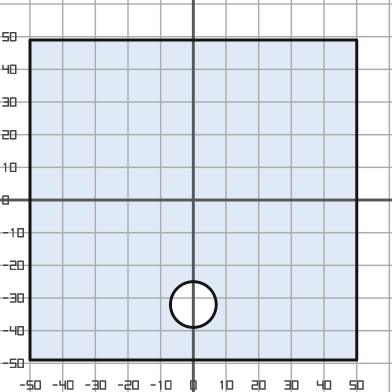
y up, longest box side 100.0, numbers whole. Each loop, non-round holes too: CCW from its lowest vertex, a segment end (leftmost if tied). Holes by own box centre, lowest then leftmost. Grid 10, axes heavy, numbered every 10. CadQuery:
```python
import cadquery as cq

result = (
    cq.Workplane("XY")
    .moveTo(-50.0, -49.0)
    .lineTo(50.0, -49.0)
    .lineTo(50.0, 49.0)
    .lineTo(-50.0, 49.0)
    .close()
    .moveTo(0.0, -32.0)
    .circle(7.0)
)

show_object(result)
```